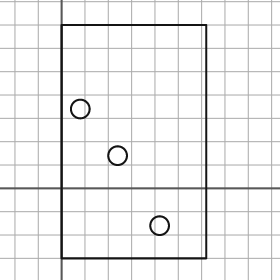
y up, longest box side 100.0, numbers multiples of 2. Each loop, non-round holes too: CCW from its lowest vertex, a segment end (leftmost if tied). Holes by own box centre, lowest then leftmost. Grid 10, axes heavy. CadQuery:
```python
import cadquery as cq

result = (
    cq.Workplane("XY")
    .moveTo(0.0, -30.0)
    .lineTo(62.0, -30.0)
    .lineTo(62.0, 70.0)
    .lineTo(0.0, 70.0)
    .close()
    .moveTo(42.0, -16.0)
    .circle(4.0)
    .moveTo(24.0, 14.0)
    .circle(4.0)
    .moveTo(8.0, 34.0)
    .circle(4.0)
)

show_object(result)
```